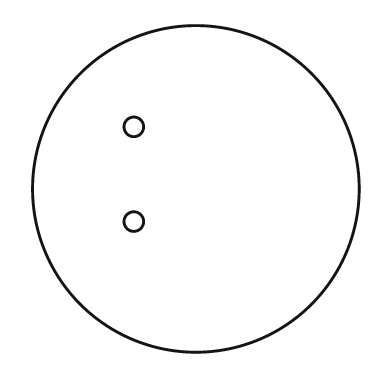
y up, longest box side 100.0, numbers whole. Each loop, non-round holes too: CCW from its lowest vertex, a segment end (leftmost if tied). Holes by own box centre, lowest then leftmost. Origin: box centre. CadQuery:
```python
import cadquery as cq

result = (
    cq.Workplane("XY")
    .moveTo(0.0, 0.0)
    .circle(50.0)
    .moveTo(-19.0, -10.0)
    .circle(3.0)
    .moveTo(-19.0, 19.0)
    .circle(3.0)
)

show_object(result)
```